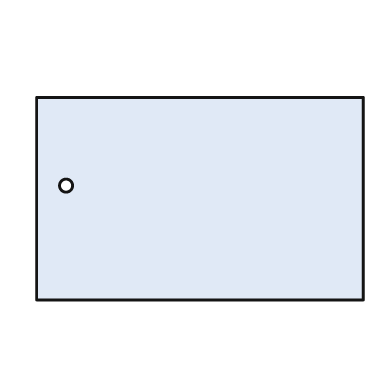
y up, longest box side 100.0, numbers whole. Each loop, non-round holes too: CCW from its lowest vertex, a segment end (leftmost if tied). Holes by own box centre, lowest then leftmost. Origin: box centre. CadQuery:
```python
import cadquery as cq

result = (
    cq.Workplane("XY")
    .moveTo(-50.0, -31.0)
    .lineTo(50.0, -31.0)
    .lineTo(50.0, 31.0)
    .lineTo(-50.0, 31.0)
    .close()
    .moveTo(-41.0, 4.0)
    .circle(2.0)
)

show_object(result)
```